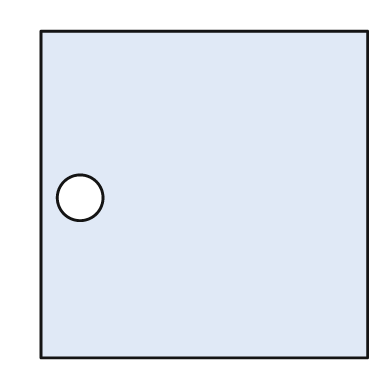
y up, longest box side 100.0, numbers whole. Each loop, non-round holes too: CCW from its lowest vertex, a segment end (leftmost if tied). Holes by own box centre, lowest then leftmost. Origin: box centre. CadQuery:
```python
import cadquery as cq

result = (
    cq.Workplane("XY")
    .moveTo(-50.0, -50.0)
    .lineTo(50.0, -50.0)
    .lineTo(50.0, 50.0)
    .lineTo(-50.0, 50.0)
    .close()
    .moveTo(-38.0, -1.0)
    .circle(7.0)
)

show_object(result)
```